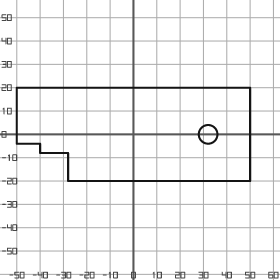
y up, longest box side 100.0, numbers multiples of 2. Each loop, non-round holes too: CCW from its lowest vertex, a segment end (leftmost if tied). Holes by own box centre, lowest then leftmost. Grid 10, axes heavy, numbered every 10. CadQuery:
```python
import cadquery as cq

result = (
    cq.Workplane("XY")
    .moveTo(-28.0, -20.0)
    .lineTo(50.0, -20.0)
    .lineTo(50.0, 20.0)
    .lineTo(-50.0, 20.0)
    .lineTo(-50.0, -4.0)
    .lineTo(-40.0, -4.0)
    .lineTo(-40.0, -8.0)
    .lineTo(-28.0, -8.0)
    .close()
    .moveTo(32.0, 0.0)
    .circle(4.0)
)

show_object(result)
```